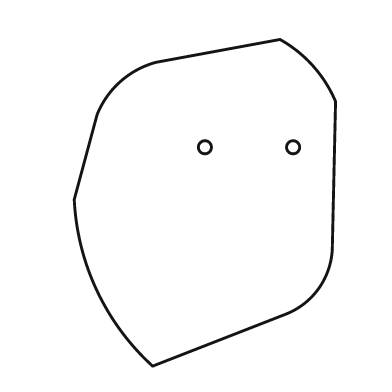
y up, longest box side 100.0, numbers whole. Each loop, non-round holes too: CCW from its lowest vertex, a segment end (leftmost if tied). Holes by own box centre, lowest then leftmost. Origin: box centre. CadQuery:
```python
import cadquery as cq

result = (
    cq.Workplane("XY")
    .moveTo(-16.0, -50.0)
    .lineTo(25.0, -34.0)
    .threePointArc((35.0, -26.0), (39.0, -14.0))
    .lineTo(40.0, 31.0)
    .threePointArc((33.0, 42.0), (23.0, 50.0))
    .lineTo(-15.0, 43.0)
    .threePointArc((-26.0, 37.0), (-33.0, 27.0))
    .lineTo(-40.0, 1.0)
    .threePointArc((-33.0, -27.0), (-16.0, -50.0))
    .close()
    .moveTo(0.0, 17.0)
    .circle(2.0)
    .moveTo(27.0, 17.0)
    .circle(2.0)
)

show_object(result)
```